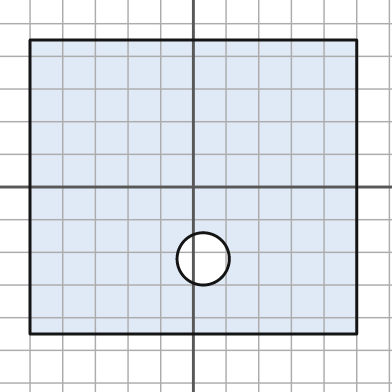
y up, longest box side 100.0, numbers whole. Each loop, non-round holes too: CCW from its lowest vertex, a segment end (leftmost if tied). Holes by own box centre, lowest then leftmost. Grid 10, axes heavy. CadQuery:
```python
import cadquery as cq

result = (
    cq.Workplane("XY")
    .moveTo(-50.0, -45.0)
    .lineTo(50.0, -45.0)
    .lineTo(50.0, 45.0)
    .lineTo(-50.0, 45.0)
    .close()
    .moveTo(3.0, -22.0)
    .circle(8.0)
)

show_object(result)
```